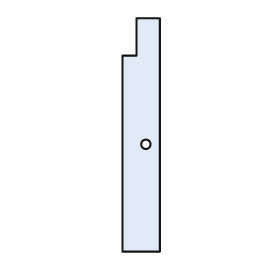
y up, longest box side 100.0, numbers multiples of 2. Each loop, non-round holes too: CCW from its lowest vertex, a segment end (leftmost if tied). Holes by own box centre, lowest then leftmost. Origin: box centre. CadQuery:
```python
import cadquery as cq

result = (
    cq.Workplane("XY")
    .moveTo(-8.0, -50.0)
    .lineTo(8.0, -50.0)
    .lineTo(8.0, 50.0)
    .lineTo(-2.0, 50.0)
    .lineTo(-2.0, 34.0)
    .lineTo(-8.0, 34.0)
    .close()
    .moveTo(2.0, -4.0)
    .circle(2.0)
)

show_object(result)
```